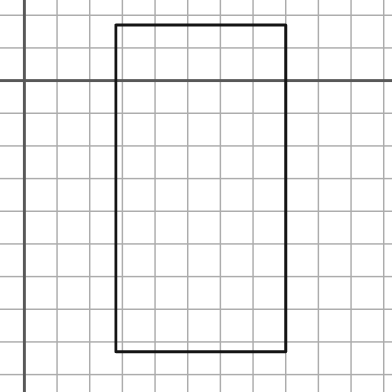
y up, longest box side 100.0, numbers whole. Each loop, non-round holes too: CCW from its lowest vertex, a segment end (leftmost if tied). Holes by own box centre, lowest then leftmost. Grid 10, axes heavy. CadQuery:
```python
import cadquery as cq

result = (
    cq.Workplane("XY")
    .moveTo(28.0, -83.0)
    .lineTo(80.0, -83.0)
    .lineTo(80.0, 17.0)
    .lineTo(28.0, 17.0)
    .close()
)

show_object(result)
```